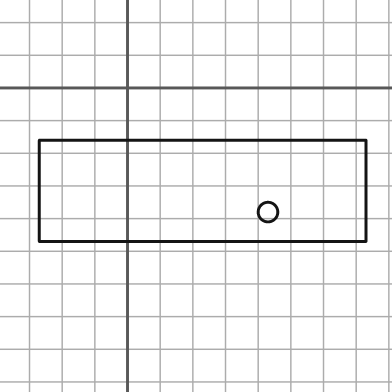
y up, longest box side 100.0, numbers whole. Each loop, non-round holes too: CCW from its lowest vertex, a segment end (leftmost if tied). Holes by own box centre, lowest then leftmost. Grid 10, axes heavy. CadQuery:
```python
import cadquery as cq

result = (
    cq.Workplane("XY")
    .moveTo(-27.0, -47.0)
    .lineTo(73.0, -47.0)
    .lineTo(73.0, -16.0)
    .lineTo(-27.0, -16.0)
    .close()
    .moveTo(43.0, -38.0)
    .circle(3.0)
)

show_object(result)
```